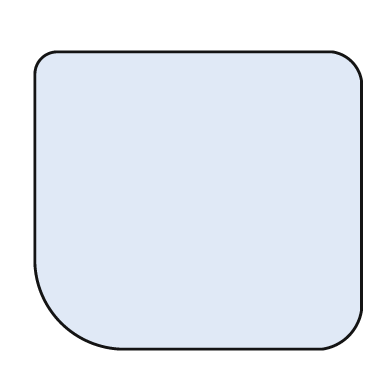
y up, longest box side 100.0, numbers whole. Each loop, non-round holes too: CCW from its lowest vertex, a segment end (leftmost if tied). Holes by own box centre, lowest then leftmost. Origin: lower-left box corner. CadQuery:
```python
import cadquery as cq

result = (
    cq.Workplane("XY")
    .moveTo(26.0, 0.0)
    .lineTo(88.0, 0.0)
    .threePointArc((96.0, 4.0), (100.0, 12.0))
    .lineTo(100.0, 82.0)
    .threePointArc((97.0, 88.0), (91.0, 91.0))
    .lineTo(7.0, 91.0)
    .threePointArc((2.0, 89.0), (0.0, 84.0))
    .lineTo(0.0, 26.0)
    .threePointArc((8.0, 8.0), (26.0, 0.0))
    .close()
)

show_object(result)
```